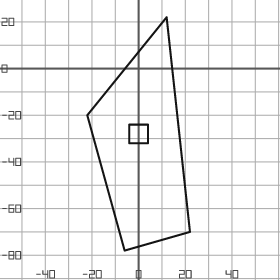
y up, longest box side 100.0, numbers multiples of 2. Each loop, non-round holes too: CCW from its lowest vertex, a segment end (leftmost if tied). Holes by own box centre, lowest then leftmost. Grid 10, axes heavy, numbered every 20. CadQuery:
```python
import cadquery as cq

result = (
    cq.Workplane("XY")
    .moveTo(-6.0, -78.0)
    .lineTo(22.0, -70.0)
    .lineTo(12.0, 22.0)
    .lineTo(-22.0, -20.0)
    .close()
    .moveTo(-4.0, -32.0)
    .lineTo(4.0, -32.0)
    .lineTo(4.0, -24.0)
    .lineTo(-4.0, -24.0)
    .close()
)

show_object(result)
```